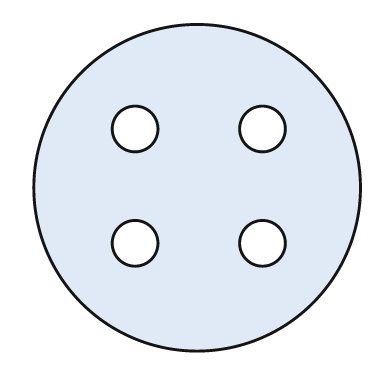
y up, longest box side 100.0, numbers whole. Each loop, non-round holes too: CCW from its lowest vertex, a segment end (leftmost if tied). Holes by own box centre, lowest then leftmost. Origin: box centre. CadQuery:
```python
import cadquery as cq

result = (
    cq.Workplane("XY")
    .moveTo(0.0, 0.0)
    .circle(50.0)
    .moveTo(-19.0, -17.0)
    .circle(7.0)
    .moveTo(20.0, -17.0)
    .circle(7.0)
    .moveTo(-19.0, 18.0)
    .circle(7.0)
    .moveTo(20.0, 18.0)
    .circle(7.0)
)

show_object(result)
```